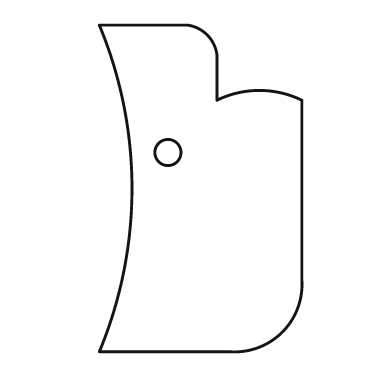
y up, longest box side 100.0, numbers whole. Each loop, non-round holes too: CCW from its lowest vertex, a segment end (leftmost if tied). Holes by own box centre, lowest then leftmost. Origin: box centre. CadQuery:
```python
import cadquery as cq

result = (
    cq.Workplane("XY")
    .moveTo(-31.0, -50.0)
    .lineTo(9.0, -50.0)
    .threePointArc((25.0, -44.0), (31.0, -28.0))
    .lineTo(31.0, 27.0)
    .threePointArc((18.0, 30.0), (5.0, 27.0))
    .lineTo(5.0, 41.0)
    .threePointArc((2.0, 47.0), (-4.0, 50.0))
    .lineTo(-31.0, 50.0)
    .threePointArc((-21.0, 0.0), (-31.0, -50.0))
    .close()
    .moveTo(-10.0, 11.0)
    .circle(4.0)
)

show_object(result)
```